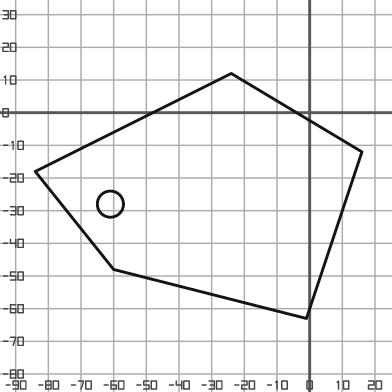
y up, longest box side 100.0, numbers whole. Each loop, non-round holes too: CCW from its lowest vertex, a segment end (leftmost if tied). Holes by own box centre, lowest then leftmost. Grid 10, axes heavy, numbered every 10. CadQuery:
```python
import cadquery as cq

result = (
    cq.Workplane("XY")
    .moveTo(-1.0, -63.0)
    .lineTo(16.0, -12.0)
    .lineTo(-24.0, 12.0)
    .lineTo(-84.0, -18.0)
    .lineTo(-60.0, -48.0)
    .close()
    .moveTo(-61.0, -28.0)
    .circle(4.0)
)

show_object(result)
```